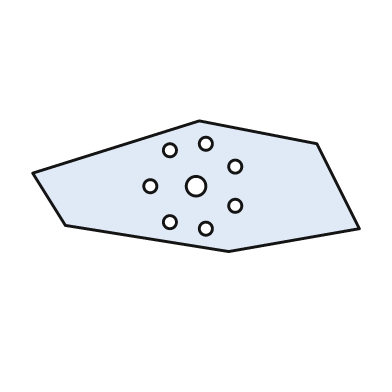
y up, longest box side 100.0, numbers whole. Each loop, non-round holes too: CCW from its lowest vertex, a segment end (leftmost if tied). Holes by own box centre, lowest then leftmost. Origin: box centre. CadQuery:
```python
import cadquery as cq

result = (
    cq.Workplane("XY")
    .moveTo(10.0, -20.0)
    .lineTo(50.0, -13.0)
    .lineTo(37.0, 13.0)
    .lineTo(1.0, 20.0)
    .lineTo(-50.0, 4.0)
    .lineTo(-40.0, -12.0)
    .close()
    .moveTo(3.0, -13.0)
    .circle(2.0)
    .moveTo(-8.0, -11.0)
    .circle(2.0)
    .moveTo(12.0, -6.0)
    .circle(2.0)
    .moveTo(-14.0, 0.0)
    .circle(2.0)
    .moveTo(0.0, 0.0)
    .circle(3.0)
    .moveTo(12.0, 6.0)
    .circle(2.0)
    .moveTo(-8.0, 11.0)
    .circle(2.0)
    .moveTo(3.0, 13.0)
    .circle(2.0)
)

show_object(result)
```